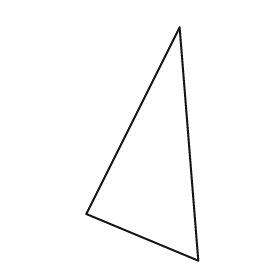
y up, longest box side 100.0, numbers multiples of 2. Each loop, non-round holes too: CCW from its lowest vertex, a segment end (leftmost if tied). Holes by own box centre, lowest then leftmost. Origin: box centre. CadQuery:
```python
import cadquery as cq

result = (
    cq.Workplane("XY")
    .moveTo(24.0, -50.0)
    .lineTo(16.0, 50.0)
    .lineTo(-24.0, -30.0)
    .close()
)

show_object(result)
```